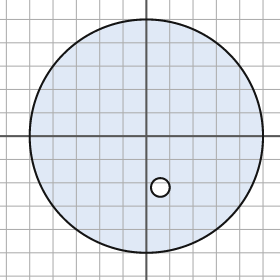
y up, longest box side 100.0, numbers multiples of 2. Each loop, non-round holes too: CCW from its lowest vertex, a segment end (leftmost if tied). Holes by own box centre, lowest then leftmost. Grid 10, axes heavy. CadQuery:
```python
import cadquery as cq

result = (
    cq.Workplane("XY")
    .moveTo(0.0, 0.0)
    .circle(50.0)
    .moveTo(6.0, -22.0)
    .circle(4.0)
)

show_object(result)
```